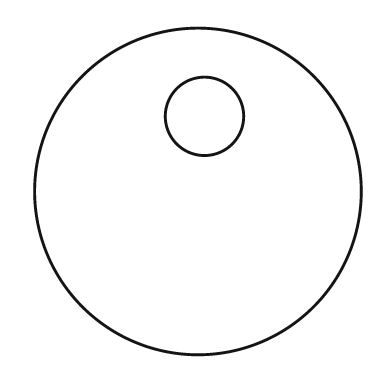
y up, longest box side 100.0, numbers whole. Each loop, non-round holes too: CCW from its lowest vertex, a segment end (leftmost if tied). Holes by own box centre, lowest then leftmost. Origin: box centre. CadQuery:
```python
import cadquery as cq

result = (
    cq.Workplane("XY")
    .moveTo(0.0, 0.0)
    .circle(50.0)
    .moveTo(2.0, 23.0)
    .circle(12.0)
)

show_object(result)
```